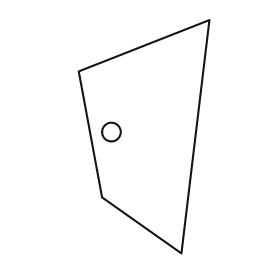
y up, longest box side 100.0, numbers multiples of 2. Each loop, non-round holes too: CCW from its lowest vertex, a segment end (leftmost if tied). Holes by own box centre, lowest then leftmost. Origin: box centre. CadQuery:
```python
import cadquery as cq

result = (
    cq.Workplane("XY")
    .moveTo(16.0, -50.0)
    .lineTo(28.0, 50.0)
    .lineTo(-28.0, 28.0)
    .lineTo(-18.0, -26.0)
    .close()
    .moveTo(-14.0, 2.0)
    .circle(4.0)
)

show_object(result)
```